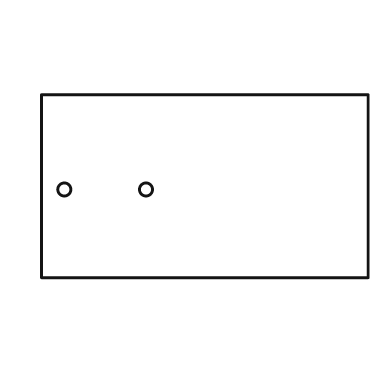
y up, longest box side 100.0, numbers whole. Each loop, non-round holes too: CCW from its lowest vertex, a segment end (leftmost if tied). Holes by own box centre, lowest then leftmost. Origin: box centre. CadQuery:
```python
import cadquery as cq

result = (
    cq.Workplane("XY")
    .moveTo(-50.0, -28.0)
    .lineTo(50.0, -28.0)
    .lineTo(50.0, 28.0)
    .lineTo(-50.0, 28.0)
    .close()
    .moveTo(-43.0, -1.0)
    .circle(2.0)
    .moveTo(-18.0, -1.0)
    .circle(2.0)
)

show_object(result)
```